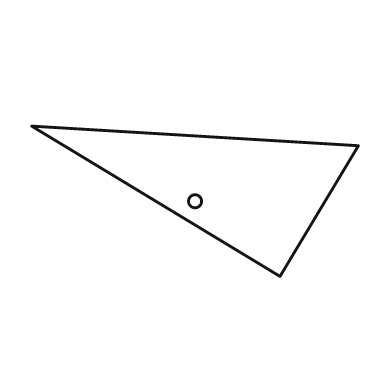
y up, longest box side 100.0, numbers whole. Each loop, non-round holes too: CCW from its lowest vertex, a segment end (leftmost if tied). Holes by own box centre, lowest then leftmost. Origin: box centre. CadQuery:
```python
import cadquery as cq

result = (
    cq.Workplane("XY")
    .moveTo(26.0, -23.0)
    .lineTo(50.0, 17.0)
    .lineTo(-50.0, 23.0)
    .close()
    .moveTo(0.0, 0.0)
    .circle(2.0)
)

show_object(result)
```